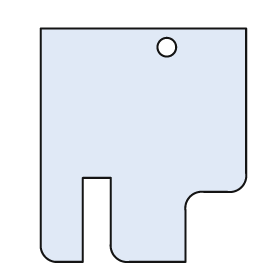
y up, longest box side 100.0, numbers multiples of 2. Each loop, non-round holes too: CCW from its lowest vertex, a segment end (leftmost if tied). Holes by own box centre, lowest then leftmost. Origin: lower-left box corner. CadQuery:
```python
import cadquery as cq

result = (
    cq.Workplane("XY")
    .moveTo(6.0, 0.0)
    .lineTo(18.0, 0.0)
    .lineTo(18.0, 36.0)
    .lineTo(30.0, 36.0)
    .lineTo(30.0, 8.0)
    .threePointArc((32.0, 2.0), (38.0, 0.0))
    .lineTo(62.0, 0.0)
    .lineTo(62.0, 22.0)
    .threePointArc((64.0, 28.0), (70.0, 30.0))
    .lineTo(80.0, 30.0)
    .threePointArc((86.0, 32.0), (88.0, 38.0))
    .lineTo(88.0, 100.0)
    .lineTo(0.0, 100.0)
    .lineTo(0.0, 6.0)
    .threePointArc((2.0, 2.0), (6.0, 0.0))
    .close()
    .moveTo(54.0, 92.0)
    .circle(4.0)
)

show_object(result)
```